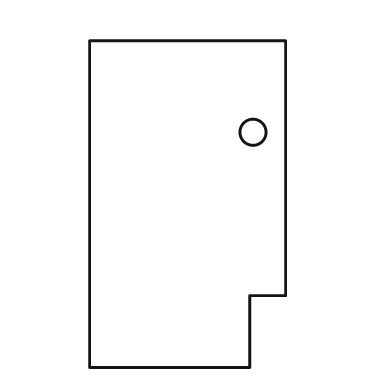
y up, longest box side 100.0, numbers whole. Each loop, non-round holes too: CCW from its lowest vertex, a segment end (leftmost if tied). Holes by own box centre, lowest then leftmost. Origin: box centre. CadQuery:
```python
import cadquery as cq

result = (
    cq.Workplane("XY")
    .moveTo(-30.0, -50.0)
    .lineTo(19.0, -50.0)
    .lineTo(19.0, -28.0)
    .lineTo(30.0, -28.0)
    .lineTo(30.0, 50.0)
    .lineTo(-30.0, 50.0)
    .close()
    .moveTo(20.0, 22.0)
    .circle(4.0)
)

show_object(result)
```